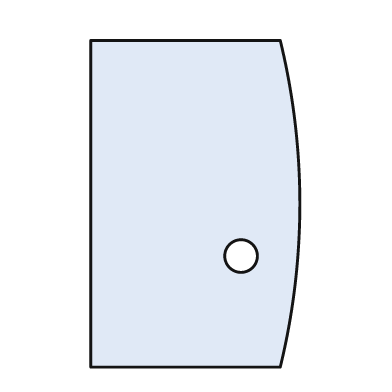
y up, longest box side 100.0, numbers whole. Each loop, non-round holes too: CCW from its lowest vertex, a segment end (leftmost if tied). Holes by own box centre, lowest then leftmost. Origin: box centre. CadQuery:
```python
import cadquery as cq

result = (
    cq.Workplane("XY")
    .moveTo(-32.0, -50.0)
    .lineTo(26.0, -50.0)
    .threePointArc((32.0, 0.0), (26.0, 50.0))
    .lineTo(-32.0, 50.0)
    .close()
    .moveTo(14.0, -16.0)
    .circle(5.0)
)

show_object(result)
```